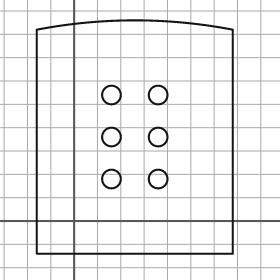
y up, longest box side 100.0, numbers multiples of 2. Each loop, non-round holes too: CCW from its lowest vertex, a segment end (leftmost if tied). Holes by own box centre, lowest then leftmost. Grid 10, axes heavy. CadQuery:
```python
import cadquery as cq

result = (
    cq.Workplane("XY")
    .moveTo(-16.0, -14.0)
    .lineTo(68.0, -14.0)
    .lineTo(68.0, 82.0)
    .threePointArc((26.0, 86.0), (-16.0, 82.0))
    .close()
    .moveTo(16.0, 18.0)
    .circle(4.0)
    .moveTo(36.0, 18.0)
    .circle(4.0)
    .moveTo(16.0, 36.0)
    .circle(4.0)
    .moveTo(36.0, 36.0)
    .circle(4.0)
    .moveTo(16.0, 54.0)
    .circle(4.0)
    .moveTo(36.0, 54.0)
    .circle(4.0)
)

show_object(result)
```